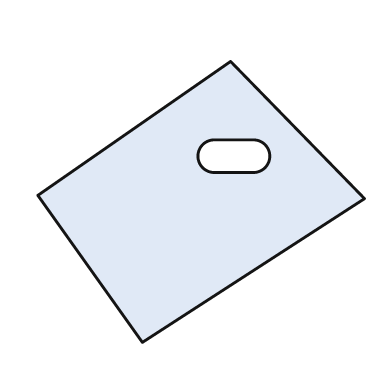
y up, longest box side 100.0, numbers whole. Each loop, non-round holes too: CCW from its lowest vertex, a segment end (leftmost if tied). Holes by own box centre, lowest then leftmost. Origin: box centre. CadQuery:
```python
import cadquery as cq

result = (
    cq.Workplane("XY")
    .moveTo(-18.0, -43.0)
    .lineTo(50.0, 1.0)
    .lineTo(9.0, 43.0)
    .lineTo(-50.0, 2.0)
    .close()
    .moveTo(4.0, 9.0)
    .lineTo(16.0, 9.0)
    .threePointArc((21.0, 14.0), (16.0, 19.0))
    .lineTo(4.0, 19.0)
    .threePointArc((-1.0, 14.0), (4.0, 9.0))
    .close()
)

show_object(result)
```